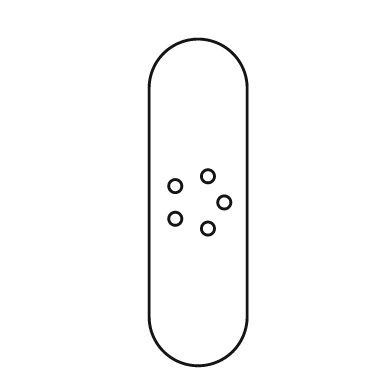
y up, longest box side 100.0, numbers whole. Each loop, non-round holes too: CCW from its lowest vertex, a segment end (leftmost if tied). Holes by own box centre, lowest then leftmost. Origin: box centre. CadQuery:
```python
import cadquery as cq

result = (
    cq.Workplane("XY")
    .moveTo(-15.0, -35.0)
    .threePointArc((0.0, -50.0), (15.0, -35.0))
    .lineTo(15.0, 35.0)
    .threePointArc((0.0, 50.0), (-15.0, 35.0))
    .close()
    .moveTo(3.0, -8.0)
    .circle(2.0)
    .moveTo(-7.0, -5.0)
    .circle(2.0)
    .moveTo(8.0, 0.0)
    .circle(2.0)
    .moveTo(-7.0, 5.0)
    .circle(2.0)
    .moveTo(3.0, 8.0)
    .circle(2.0)
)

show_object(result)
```